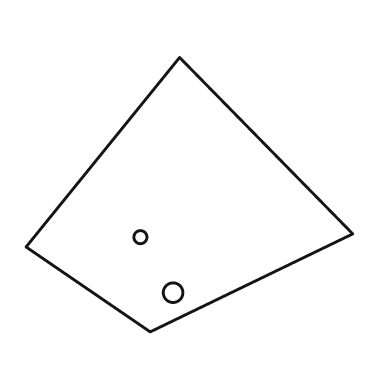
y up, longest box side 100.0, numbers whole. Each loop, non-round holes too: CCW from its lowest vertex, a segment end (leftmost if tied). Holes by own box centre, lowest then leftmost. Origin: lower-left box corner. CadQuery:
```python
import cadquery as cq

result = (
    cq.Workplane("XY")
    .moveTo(38.0, 0.0)
    .lineTo(100.0, 30.0)
    .lineTo(47.0, 84.0)
    .lineTo(0.0, 26.0)
    .close()
    .moveTo(45.0, 12.0)
    .circle(3.0)
    .moveTo(35.0, 29.0)
    .circle(2.0)
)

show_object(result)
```